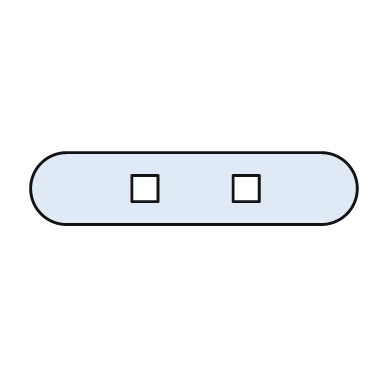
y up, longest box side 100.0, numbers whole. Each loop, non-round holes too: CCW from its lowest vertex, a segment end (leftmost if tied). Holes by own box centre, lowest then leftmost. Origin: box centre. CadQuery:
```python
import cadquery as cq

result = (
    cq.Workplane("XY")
    .moveTo(-39.0, -11.0)
    .lineTo(39.0, -11.0)
    .threePointArc((50.0, 0.0), (39.0, 11.0))
    .lineTo(-39.0, 11.0)
    .threePointArc((-50.0, 0.0), (-39.0, -11.0))
    .close()
    .moveTo(-19.0, -4.0)
    .lineTo(-11.0, -4.0)
    .lineTo(-11.0, 4.0)
    .lineTo(-19.0, 4.0)
    .close()
    .moveTo(12.0, -4.0)
    .lineTo(20.0, -4.0)
    .lineTo(20.0, 4.0)
    .lineTo(12.0, 4.0)
    .close()
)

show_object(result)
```